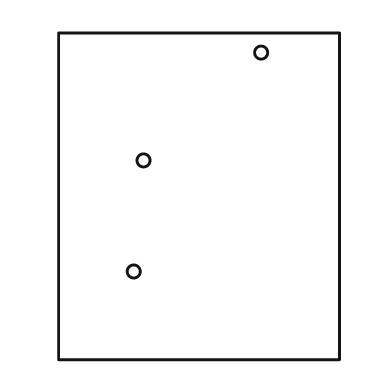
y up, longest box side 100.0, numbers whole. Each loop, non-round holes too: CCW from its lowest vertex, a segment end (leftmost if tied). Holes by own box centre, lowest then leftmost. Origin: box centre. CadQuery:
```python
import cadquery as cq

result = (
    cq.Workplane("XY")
    .moveTo(-43.0, -50.0)
    .lineTo(43.0, -50.0)
    .lineTo(43.0, 50.0)
    .lineTo(-43.0, 50.0)
    .close()
    .moveTo(-20.0, -23.0)
    .circle(2.0)
    .moveTo(-17.0, 11.0)
    .circle(2.0)
    .moveTo(19.0, 44.0)
    .circle(2.0)
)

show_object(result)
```